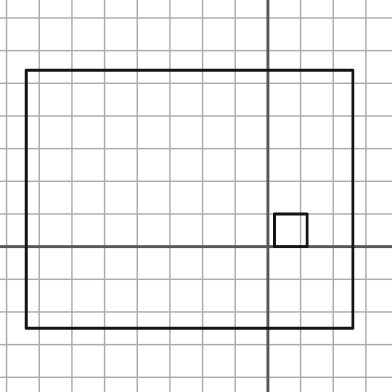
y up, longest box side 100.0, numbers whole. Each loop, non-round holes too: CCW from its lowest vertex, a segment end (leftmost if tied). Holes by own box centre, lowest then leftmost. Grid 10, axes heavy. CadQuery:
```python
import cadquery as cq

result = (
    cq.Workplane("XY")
    .moveTo(-74.0, -25.0)
    .lineTo(26.0, -25.0)
    .lineTo(26.0, 54.0)
    .lineTo(-74.0, 54.0)
    .close()
    .moveTo(2.0, 0.0)
    .lineTo(12.0, 0.0)
    .lineTo(12.0, 10.0)
    .lineTo(2.0, 10.0)
    .close()
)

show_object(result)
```